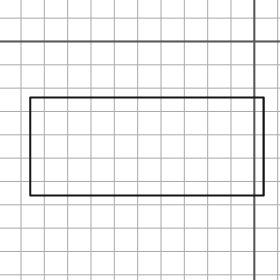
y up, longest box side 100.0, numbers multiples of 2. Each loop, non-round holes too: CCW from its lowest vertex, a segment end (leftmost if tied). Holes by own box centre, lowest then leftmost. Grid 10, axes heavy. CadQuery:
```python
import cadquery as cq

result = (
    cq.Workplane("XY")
    .moveTo(-96.0, -66.0)
    .lineTo(4.0, -66.0)
    .lineTo(4.0, -24.0)
    .lineTo(-96.0, -24.0)
    .close()
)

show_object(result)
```